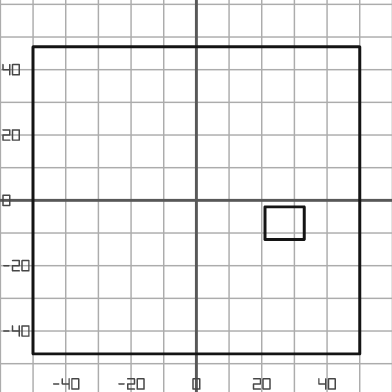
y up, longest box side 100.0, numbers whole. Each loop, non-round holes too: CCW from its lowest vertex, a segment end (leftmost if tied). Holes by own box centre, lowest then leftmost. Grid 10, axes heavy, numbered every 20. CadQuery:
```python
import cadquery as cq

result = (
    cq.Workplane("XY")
    .moveTo(-50.0, -47.0)
    .lineTo(50.0, -47.0)
    .lineTo(50.0, 47.0)
    .lineTo(-50.0, 47.0)
    .close()
    .moveTo(21.0, -12.0)
    .lineTo(33.0, -12.0)
    .lineTo(33.0, -2.0)
    .lineTo(21.0, -2.0)
    .close()
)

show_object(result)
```